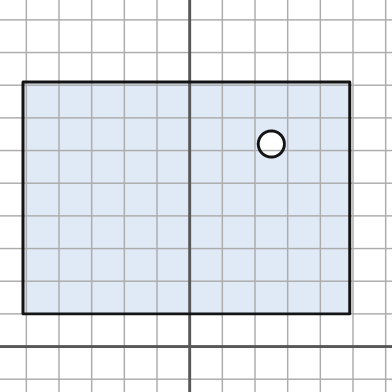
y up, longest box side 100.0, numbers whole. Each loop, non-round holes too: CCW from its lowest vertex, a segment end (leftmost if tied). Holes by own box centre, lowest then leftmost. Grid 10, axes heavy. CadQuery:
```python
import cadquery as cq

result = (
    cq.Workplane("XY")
    .moveTo(-51.0, 10.0)
    .lineTo(49.0, 10.0)
    .lineTo(49.0, 81.0)
    .lineTo(-51.0, 81.0)
    .close()
    .moveTo(25.0, 62.0)
    .circle(4.0)
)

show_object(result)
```